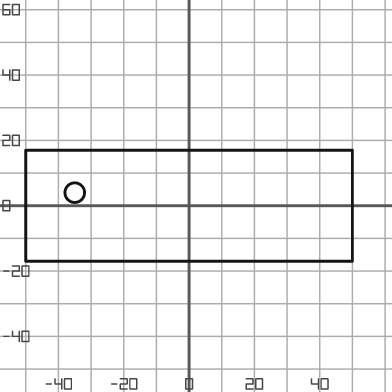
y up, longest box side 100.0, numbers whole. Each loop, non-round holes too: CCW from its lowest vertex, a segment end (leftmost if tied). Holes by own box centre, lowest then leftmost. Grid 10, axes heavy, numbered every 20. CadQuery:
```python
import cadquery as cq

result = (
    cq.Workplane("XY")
    .moveTo(-50.0, -17.0)
    .lineTo(50.0, -17.0)
    .lineTo(50.0, 17.0)
    .lineTo(-50.0, 17.0)
    .close()
    .moveTo(-35.0, 4.0)
    .circle(3.0)
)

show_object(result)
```